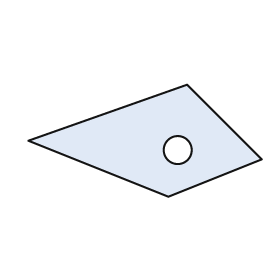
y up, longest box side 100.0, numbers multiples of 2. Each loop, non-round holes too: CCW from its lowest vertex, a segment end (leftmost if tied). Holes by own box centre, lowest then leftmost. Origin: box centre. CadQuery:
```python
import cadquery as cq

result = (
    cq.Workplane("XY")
    .moveTo(10.0, -24.0)
    .lineTo(50.0, -8.0)
    .lineTo(18.0, 24.0)
    .lineTo(-50.0, 0.0)
    .close()
    .moveTo(14.0, -4.0)
    .circle(6.0)
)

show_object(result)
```